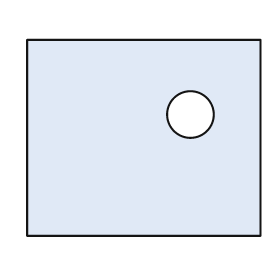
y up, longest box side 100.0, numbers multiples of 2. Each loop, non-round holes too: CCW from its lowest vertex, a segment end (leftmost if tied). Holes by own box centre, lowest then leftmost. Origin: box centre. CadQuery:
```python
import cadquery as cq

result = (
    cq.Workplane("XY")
    .moveTo(-50.0, -42.0)
    .lineTo(50.0, -42.0)
    .lineTo(50.0, 42.0)
    .lineTo(-50.0, 42.0)
    .close()
    .moveTo(20.0, 10.0)
    .circle(10.0)
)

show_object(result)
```